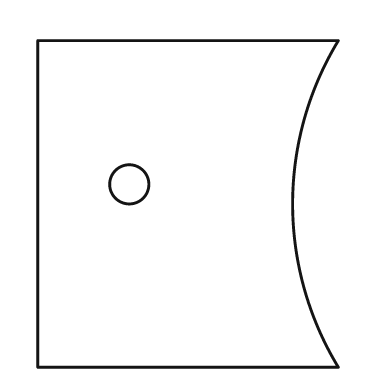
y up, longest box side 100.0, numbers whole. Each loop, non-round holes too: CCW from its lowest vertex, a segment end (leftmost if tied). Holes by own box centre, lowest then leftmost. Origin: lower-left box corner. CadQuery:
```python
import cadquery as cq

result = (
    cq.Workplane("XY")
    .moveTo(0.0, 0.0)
    .lineTo(92.0, 0.0)
    .threePointArc((78.0, 50.0), (92.0, 100.0))
    .lineTo(0.0, 100.0)
    .close()
    .moveTo(28.0, 56.0)
    .circle(6.0)
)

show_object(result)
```